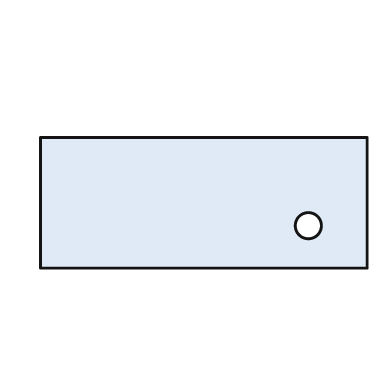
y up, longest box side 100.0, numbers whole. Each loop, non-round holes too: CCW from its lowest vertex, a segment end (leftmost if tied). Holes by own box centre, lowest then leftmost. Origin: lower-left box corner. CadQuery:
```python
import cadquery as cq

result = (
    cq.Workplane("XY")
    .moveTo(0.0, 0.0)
    .lineTo(100.0, 0.0)
    .lineTo(100.0, 40.0)
    .lineTo(0.0, 40.0)
    .close()
    .moveTo(82.0, 13.0)
    .circle(4.0)
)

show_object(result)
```